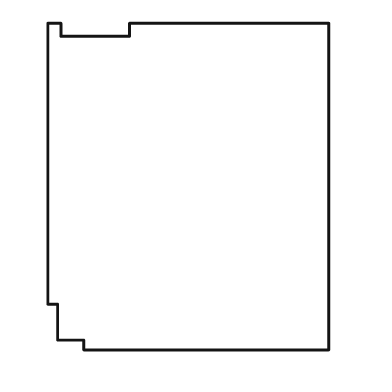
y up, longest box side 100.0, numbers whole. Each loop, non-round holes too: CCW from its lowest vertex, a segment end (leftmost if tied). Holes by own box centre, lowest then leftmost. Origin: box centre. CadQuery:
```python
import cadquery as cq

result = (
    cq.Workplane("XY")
    .moveTo(-32.0, -50.0)
    .lineTo(43.0, -50.0)
    .lineTo(43.0, 50.0)
    .lineTo(-18.0, 50.0)
    .lineTo(-18.0, 46.0)
    .lineTo(-39.0, 46.0)
    .lineTo(-39.0, 50.0)
    .lineTo(-43.0, 50.0)
    .lineTo(-43.0, -36.0)
    .lineTo(-40.0, -36.0)
    .lineTo(-40.0, -47.0)
    .lineTo(-32.0, -47.0)
    .close()
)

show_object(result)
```